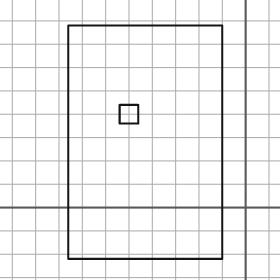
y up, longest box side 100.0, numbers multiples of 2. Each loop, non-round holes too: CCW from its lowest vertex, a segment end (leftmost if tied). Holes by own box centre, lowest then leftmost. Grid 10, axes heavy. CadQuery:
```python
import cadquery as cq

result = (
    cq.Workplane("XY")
    .moveTo(-76.0, -22.0)
    .lineTo(-10.0, -22.0)
    .lineTo(-10.0, 78.0)
    .lineTo(-76.0, 78.0)
    .close()
    .moveTo(-54.0, 36.0)
    .lineTo(-46.0, 36.0)
    .lineTo(-46.0, 44.0)
    .lineTo(-54.0, 44.0)
    .close()
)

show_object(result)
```